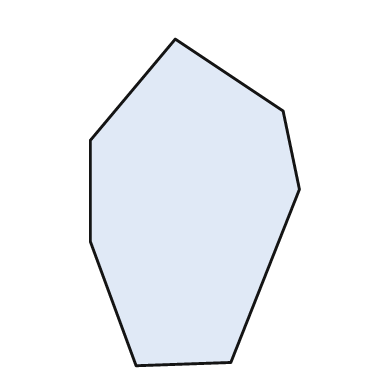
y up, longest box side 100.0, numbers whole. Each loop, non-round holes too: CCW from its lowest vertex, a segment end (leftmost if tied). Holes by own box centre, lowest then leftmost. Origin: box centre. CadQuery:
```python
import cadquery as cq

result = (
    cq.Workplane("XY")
    .moveTo(-18.0, -50.0)
    .lineTo(11.0, -49.0)
    .lineTo(32.0, 4.0)
    .lineTo(27.0, 28.0)
    .lineTo(-6.0, 50.0)
    .lineTo(-32.0, 19.0)
    .lineTo(-32.0, -12.0)
    .close()
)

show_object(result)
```